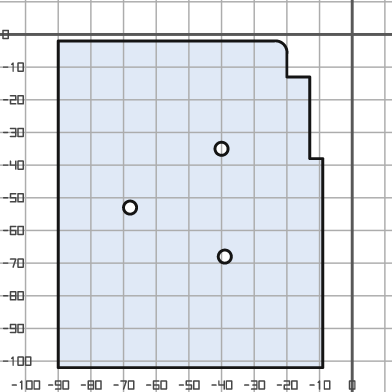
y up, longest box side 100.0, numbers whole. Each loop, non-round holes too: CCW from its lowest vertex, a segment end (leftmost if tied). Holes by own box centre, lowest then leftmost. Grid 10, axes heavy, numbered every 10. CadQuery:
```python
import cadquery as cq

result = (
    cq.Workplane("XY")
    .moveTo(-90.0, -102.0)
    .lineTo(-9.0, -102.0)
    .lineTo(-9.0, -38.0)
    .lineTo(-13.0, -38.0)
    .lineTo(-13.0, -13.0)
    .lineTo(-20.0, -13.0)
    .lineTo(-20.0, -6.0)
    .threePointArc((-21.0, -3.0), (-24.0, -2.0))
    .lineTo(-90.0, -2.0)
    .close()
    .moveTo(-39.0, -68.0)
    .circle(2.0)
    .moveTo(-68.0, -53.0)
    .circle(2.0)
    .moveTo(-40.0, -35.0)
    .circle(2.0)
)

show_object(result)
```